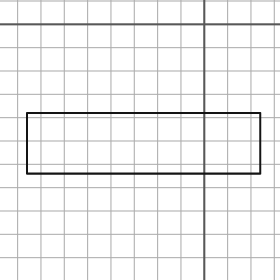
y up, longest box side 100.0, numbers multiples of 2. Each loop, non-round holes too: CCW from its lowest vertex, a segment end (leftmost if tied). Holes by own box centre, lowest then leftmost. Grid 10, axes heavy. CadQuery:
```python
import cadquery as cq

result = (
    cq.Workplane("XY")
    .moveTo(-76.0, -64.0)
    .lineTo(24.0, -64.0)
    .lineTo(24.0, -38.0)
    .lineTo(-76.0, -38.0)
    .close()
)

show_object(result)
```